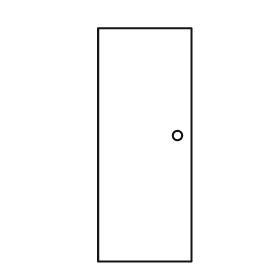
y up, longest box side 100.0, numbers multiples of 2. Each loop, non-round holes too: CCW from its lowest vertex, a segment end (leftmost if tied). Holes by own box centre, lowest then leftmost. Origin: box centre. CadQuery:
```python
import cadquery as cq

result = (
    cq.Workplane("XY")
    .moveTo(-20.0, -50.0)
    .lineTo(20.0, -50.0)
    .lineTo(20.0, 50.0)
    .lineTo(-20.0, 50.0)
    .close()
    .moveTo(14.0, 4.0)
    .circle(2.0)
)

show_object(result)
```